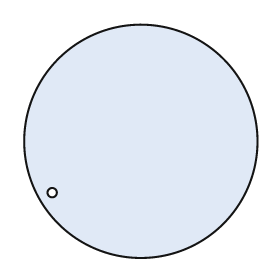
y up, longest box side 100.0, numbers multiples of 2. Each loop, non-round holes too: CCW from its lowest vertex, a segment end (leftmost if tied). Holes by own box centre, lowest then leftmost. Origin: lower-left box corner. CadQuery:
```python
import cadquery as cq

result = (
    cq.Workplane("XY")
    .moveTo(50.0, 50.0)
    .circle(50.0)
    .moveTo(12.0, 28.0)
    .circle(2.0)
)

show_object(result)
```